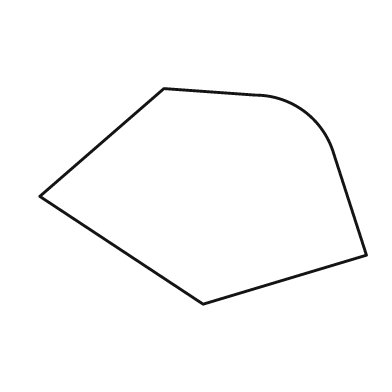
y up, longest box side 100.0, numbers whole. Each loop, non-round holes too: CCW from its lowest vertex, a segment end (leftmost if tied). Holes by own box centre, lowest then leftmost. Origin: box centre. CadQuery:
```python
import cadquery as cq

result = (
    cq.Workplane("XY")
    .moveTo(0.0, -33.0)
    .lineTo(50.0, -18.0)
    .lineTo(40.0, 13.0)
    .threePointArc((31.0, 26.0), (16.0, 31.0))
    .lineTo(-12.0, 33.0)
    .lineTo(-50.0, 0.0)
    .close()
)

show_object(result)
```